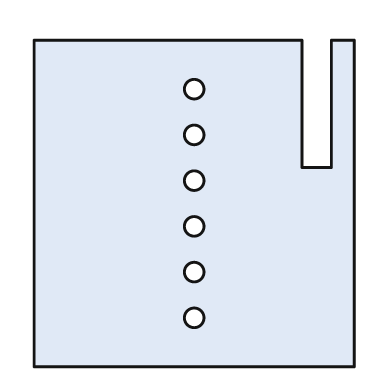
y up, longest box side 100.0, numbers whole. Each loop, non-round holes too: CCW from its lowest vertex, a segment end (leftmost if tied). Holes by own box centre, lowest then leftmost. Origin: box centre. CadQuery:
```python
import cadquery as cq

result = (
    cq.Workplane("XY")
    .moveTo(-49.0, -50.0)
    .lineTo(49.0, -50.0)
    .lineTo(49.0, 50.0)
    .lineTo(42.0, 50.0)
    .lineTo(42.0, 11.0)
    .lineTo(33.0, 11.0)
    .lineTo(33.0, 50.0)
    .lineTo(-49.0, 50.0)
    .close()
    .moveTo(0.0, -35.0)
    .circle(3.0)
    .moveTo(0.0, -21.0)
    .circle(3.0)
    .moveTo(0.0, -7.0)
    .circle(3.0)
    .moveTo(0.0, 7.0)
    .circle(3.0)
    .moveTo(0.0, 21.0)
    .circle(3.0)
    .moveTo(0.0, 35.0)
    .circle(3.0)
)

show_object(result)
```